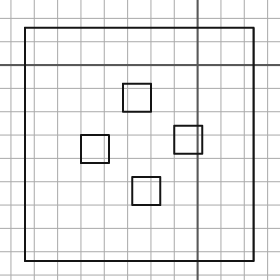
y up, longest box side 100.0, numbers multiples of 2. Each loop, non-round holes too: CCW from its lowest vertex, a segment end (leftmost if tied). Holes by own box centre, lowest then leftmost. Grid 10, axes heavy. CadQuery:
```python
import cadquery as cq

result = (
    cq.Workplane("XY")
    .moveTo(-74.0, -84.0)
    .lineTo(24.0, -84.0)
    .lineTo(24.0, 16.0)
    .lineTo(-74.0, 16.0)
    .close()
    .moveTo(-28.0, -60.0)
    .lineTo(-16.0, -60.0)
    .lineTo(-16.0, -48.0)
    .lineTo(-28.0, -48.0)
    .close()
    .moveTo(-50.0, -42.0)
    .lineTo(-38.0, -42.0)
    .lineTo(-38.0, -30.0)
    .lineTo(-50.0, -30.0)
    .close()
    .moveTo(-10.0, -38.0)
    .lineTo(2.0, -38.0)
    .lineTo(2.0, -26.0)
    .lineTo(-10.0, -26.0)
    .close()
    .moveTo(-32.0, -20.0)
    .lineTo(-20.0, -20.0)
    .lineTo(-20.0, -8.0)
    .lineTo(-32.0, -8.0)
    .close()
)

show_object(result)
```